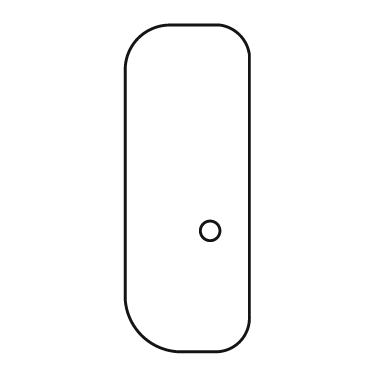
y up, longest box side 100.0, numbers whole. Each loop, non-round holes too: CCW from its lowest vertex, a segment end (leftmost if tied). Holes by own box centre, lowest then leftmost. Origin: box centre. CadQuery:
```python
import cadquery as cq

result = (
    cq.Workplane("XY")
    .moveTo(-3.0, -50.0)
    .lineTo(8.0, -50.0)
    .threePointArc((16.0, -47.0), (19.0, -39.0))
    .lineTo(19.0, 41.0)
    .threePointArc((16.0, 47.0), (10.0, 50.0))
    .lineTo(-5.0, 50.0)
    .threePointArc((-15.0, 46.0), (-19.0, 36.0))
    .lineTo(-19.0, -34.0)
    .threePointArc((-14.0, -45.0), (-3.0, -50.0))
    .close()
    .moveTo(7.0, -13.0)
    .circle(3.0)
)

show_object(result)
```